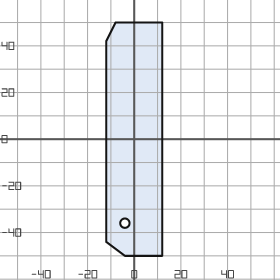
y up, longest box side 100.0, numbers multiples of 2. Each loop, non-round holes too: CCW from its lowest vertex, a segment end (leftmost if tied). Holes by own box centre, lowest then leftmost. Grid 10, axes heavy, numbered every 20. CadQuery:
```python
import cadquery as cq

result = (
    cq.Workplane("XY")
    .moveTo(-4.0, -50.0)
    .lineTo(12.0, -50.0)
    .lineTo(12.0, 50.0)
    .lineTo(-8.0, 50.0)
    .lineTo(-12.0, 42.0)
    .lineTo(-12.0, -44.0)
    .close()
    .moveTo(-4.0, -36.0)
    .circle(2.0)
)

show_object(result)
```